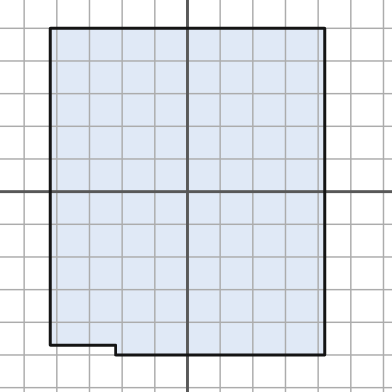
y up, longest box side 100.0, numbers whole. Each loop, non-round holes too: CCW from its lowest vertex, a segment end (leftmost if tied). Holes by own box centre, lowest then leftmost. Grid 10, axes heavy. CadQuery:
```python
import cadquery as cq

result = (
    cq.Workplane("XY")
    .moveTo(-22.0, -50.0)
    .lineTo(42.0, -50.0)
    .lineTo(42.0, 50.0)
    .lineTo(-42.0, 50.0)
    .lineTo(-42.0, -47.0)
    .lineTo(-22.0, -47.0)
    .close()
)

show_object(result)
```